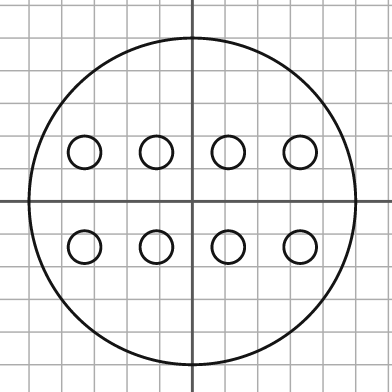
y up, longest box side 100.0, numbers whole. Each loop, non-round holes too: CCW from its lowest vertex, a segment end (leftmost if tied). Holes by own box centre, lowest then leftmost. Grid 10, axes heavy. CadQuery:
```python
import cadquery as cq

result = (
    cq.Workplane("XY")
    .moveTo(0.0, 0.0)
    .circle(50.0)
    .moveTo(-33.0, -14.0)
    .circle(5.0)
    .moveTo(-11.0, -14.0)
    .circle(5.0)
    .moveTo(11.0, -14.0)
    .circle(5.0)
    .moveTo(33.0, -14.0)
    .circle(5.0)
    .moveTo(-33.0, 15.0)
    .circle(5.0)
    .moveTo(-11.0, 15.0)
    .circle(5.0)
    .moveTo(11.0, 15.0)
    .circle(5.0)
    .moveTo(33.0, 15.0)
    .circle(5.0)
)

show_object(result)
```